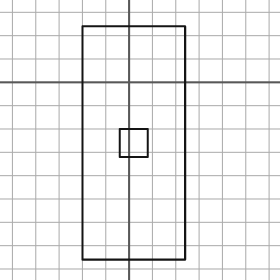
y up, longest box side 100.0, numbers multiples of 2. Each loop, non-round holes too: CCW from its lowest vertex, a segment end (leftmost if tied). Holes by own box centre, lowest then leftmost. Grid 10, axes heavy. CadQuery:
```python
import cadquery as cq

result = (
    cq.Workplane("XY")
    .moveTo(-20.0, -76.0)
    .lineTo(24.0, -76.0)
    .lineTo(24.0, 24.0)
    .lineTo(-20.0, 24.0)
    .close()
    .moveTo(-4.0, -32.0)
    .lineTo(8.0, -32.0)
    .lineTo(8.0, -20.0)
    .lineTo(-4.0, -20.0)
    .close()
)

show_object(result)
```